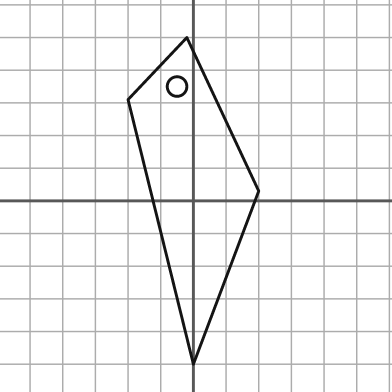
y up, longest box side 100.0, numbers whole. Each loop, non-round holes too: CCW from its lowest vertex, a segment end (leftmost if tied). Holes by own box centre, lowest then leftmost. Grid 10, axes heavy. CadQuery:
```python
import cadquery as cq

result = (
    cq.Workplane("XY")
    .moveTo(0.0, -50.0)
    .lineTo(20.0, 3.0)
    .lineTo(-2.0, 50.0)
    .lineTo(-20.0, 31.0)
    .close()
    .moveTo(-5.0, 35.0)
    .circle(3.0)
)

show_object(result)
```